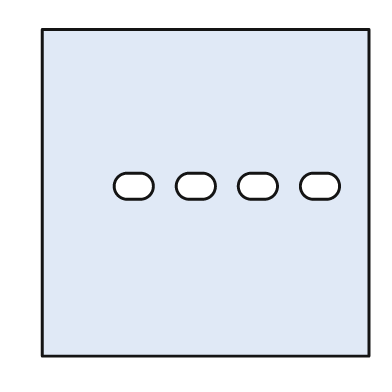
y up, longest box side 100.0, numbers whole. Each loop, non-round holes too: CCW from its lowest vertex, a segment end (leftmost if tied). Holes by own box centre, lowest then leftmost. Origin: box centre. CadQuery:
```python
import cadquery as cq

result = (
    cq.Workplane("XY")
    .moveTo(-50.0, -50.0)
    .lineTo(50.0, -50.0)
    .lineTo(50.0, 50.0)
    .lineTo(-50.0, 50.0)
    .close()
    .moveTo(-24.0, -2.0)
    .lineTo(-20.0, -2.0)
    .threePointArc((-16.0, 2.0), (-20.0, 6.0))
    .lineTo(-24.0, 6.0)
    .threePointArc((-28.0, 2.0), (-24.0, -2.0))
    .close()
    .moveTo(-5.0, -2.0)
    .lineTo(-1.0, -2.0)
    .threePointArc((3.0, 2.0), (-1.0, 6.0))
    .lineTo(-5.0, 6.0)
    .threePointArc((-9.0, 2.0), (-5.0, -2.0))
    .close()
    .moveTo(14.0, -2.0)
    .lineTo(18.0, -2.0)
    .threePointArc((22.0, 2.0), (18.0, 6.0))
    .lineTo(14.0, 6.0)
    .threePointArc((10.0, 2.0), (14.0, -2.0))
    .close()
    .moveTo(33.0, -2.0)
    .lineTo(37.0, -2.0)
    .threePointArc((41.0, 2.0), (37.0, 6.0))
    .lineTo(33.0, 6.0)
    .threePointArc((29.0, 2.0), (33.0, -2.0))
    .close()
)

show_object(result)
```